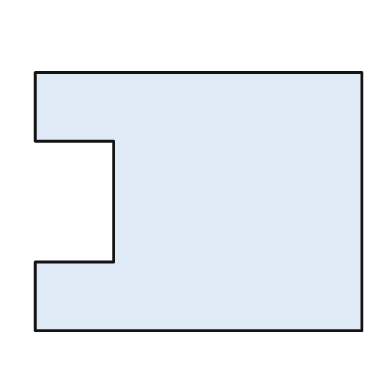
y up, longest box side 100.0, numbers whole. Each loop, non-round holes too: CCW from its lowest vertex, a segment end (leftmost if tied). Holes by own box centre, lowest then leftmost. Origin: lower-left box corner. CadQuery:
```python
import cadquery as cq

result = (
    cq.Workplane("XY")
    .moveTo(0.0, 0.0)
    .lineTo(100.0, 0.0)
    .lineTo(100.0, 79.0)
    .lineTo(0.0, 79.0)
    .lineTo(0.0, 58.0)
    .lineTo(24.0, 58.0)
    .lineTo(24.0, 21.0)
    .lineTo(0.0, 21.0)
    .close()
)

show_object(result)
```